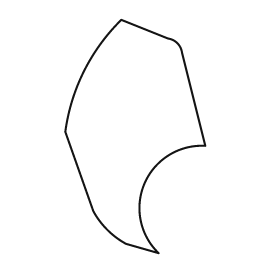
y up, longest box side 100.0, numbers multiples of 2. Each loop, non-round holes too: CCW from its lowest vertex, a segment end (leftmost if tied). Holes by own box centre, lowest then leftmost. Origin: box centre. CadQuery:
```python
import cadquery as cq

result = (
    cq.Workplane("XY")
    .moveTo(10.0, -50.0)
    .threePointArc((4.0, -20.0), (30.0, -4.0))
    .lineTo(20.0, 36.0)
    .threePointArc((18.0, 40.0), (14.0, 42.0))
    .lineTo(-6.0, 50.0)
    .threePointArc((-22.0, 28.0), (-30.0, 2.0))
    .lineTo(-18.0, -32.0)
    .threePointArc((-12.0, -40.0), (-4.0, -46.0))
    .close()
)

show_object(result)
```